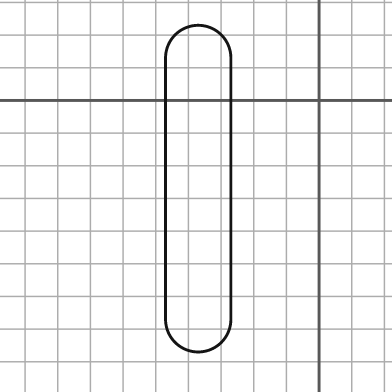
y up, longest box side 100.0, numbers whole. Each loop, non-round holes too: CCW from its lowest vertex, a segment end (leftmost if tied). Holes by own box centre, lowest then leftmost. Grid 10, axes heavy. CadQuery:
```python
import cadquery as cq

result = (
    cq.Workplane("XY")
    .moveTo(-47.0, -67.0)
    .threePointArc((-37.0, -77.0), (-27.0, -67.0))
    .lineTo(-27.0, 13.0)
    .threePointArc((-37.0, 23.0), (-47.0, 13.0))
    .close()
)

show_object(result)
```